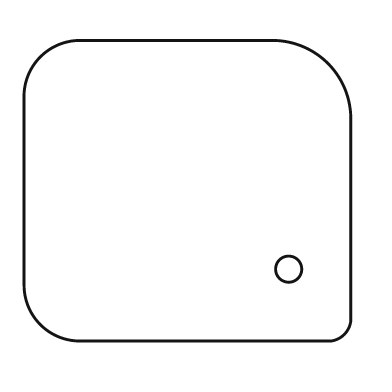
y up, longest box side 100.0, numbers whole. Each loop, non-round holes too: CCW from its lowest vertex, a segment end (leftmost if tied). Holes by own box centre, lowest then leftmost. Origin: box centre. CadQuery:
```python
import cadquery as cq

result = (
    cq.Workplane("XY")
    .moveTo(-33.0, -46.0)
    .lineTo(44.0, -46.0)
    .threePointArc((48.0, -44.0), (50.0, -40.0))
    .lineTo(50.0, 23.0)
    .threePointArc((43.0, 39.0), (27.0, 46.0))
    .lineTo(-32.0, 46.0)
    .threePointArc((-45.0, 41.0), (-50.0, 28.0))
    .lineTo(-50.0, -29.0)
    .threePointArc((-45.0, -41.0), (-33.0, -46.0))
    .close()
    .moveTo(31.0, -24.0)
    .circle(4.0)
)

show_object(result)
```